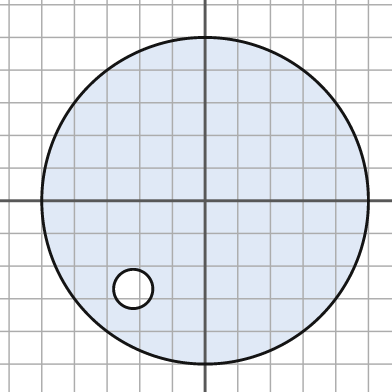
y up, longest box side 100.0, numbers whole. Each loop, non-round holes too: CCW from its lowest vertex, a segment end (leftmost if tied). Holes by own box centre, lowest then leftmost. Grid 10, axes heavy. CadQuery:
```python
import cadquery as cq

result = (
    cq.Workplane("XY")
    .moveTo(0.0, 0.0)
    .circle(50.0)
    .moveTo(-22.0, -27.0)
    .circle(6.0)
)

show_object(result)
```